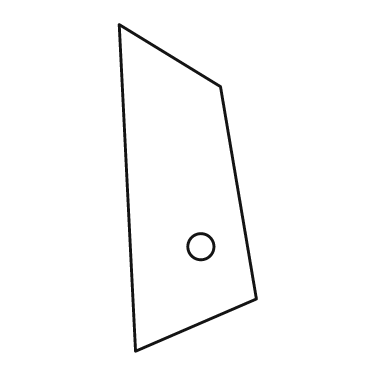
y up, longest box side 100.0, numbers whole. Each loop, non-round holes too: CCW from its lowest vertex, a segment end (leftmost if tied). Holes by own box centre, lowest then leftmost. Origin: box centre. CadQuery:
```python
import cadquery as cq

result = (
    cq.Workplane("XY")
    .moveTo(-16.0, -50.0)
    .lineTo(21.0, -34.0)
    .lineTo(10.0, 31.0)
    .lineTo(-21.0, 50.0)
    .close()
    .moveTo(4.0, -18.0)
    .circle(4.0)
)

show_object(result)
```